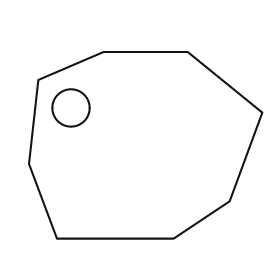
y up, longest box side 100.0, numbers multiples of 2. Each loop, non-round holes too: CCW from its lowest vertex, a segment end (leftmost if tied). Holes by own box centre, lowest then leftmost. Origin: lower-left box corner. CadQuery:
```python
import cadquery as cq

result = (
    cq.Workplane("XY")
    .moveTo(12.0, 0.0)
    .lineTo(62.0, 0.0)
    .lineTo(86.0, 16.0)
    .lineTo(100.0, 54.0)
    .lineTo(68.0, 80.0)
    .lineTo(32.0, 80.0)
    .lineTo(4.0, 68.0)
    .lineTo(0.0, 32.0)
    .close()
    .moveTo(18.0, 56.0)
    .circle(8.0)
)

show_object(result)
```